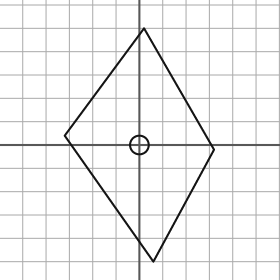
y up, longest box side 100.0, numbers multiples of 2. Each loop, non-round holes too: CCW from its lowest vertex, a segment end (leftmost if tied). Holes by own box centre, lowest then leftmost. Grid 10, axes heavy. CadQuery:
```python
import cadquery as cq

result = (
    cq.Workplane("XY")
    .moveTo(6.0, -50.0)
    .lineTo(32.0, -2.0)
    .lineTo(2.0, 50.0)
    .lineTo(-32.0, 4.0)
    .close()
    .moveTo(0.0, 0.0)
    .circle(4.0)
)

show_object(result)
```